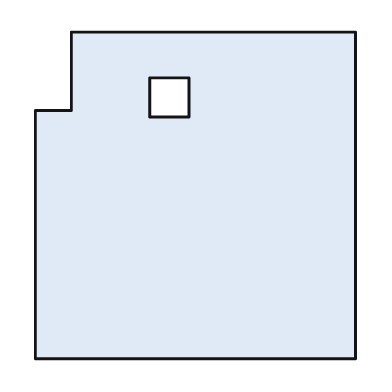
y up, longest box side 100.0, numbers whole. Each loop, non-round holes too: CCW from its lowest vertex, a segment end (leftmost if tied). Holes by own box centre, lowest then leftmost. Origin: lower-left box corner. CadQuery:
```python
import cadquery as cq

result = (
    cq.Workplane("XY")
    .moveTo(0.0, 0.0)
    .lineTo(98.0, 0.0)
    .lineTo(98.0, 100.0)
    .lineTo(11.0, 100.0)
    .lineTo(11.0, 76.0)
    .lineTo(0.0, 76.0)
    .close()
    .moveTo(35.0, 74.0)
    .lineTo(47.0, 74.0)
    .lineTo(47.0, 86.0)
    .lineTo(35.0, 86.0)
    .close()
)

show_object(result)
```